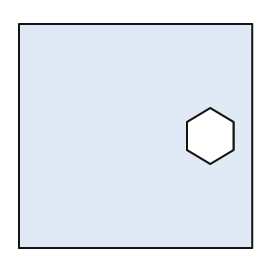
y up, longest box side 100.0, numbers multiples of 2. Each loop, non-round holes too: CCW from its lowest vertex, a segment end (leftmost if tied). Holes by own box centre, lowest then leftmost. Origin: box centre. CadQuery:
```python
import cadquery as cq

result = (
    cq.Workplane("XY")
    .moveTo(-50.0, -48.0)
    .lineTo(50.0, -48.0)
    .lineTo(50.0, 48.0)
    .lineTo(-50.0, 48.0)
    .close()
    .moveTo(32.0, -12.0)
    .lineTo(42.0, -6.0)
    .lineTo(42.0, 6.0)
    .lineTo(32.0, 12.0)
    .lineTo(22.0, 6.0)
    .lineTo(22.0, -6.0)
    .close()
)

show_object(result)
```